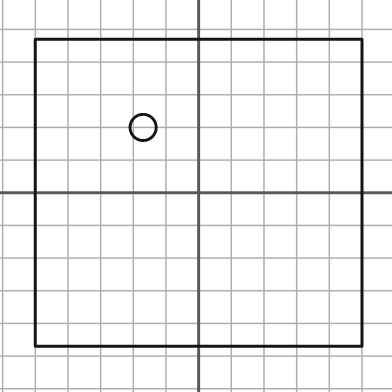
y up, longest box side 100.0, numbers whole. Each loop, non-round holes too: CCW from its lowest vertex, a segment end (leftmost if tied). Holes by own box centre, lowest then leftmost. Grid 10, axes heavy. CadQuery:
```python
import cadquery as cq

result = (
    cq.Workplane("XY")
    .moveTo(-50.0, -47.0)
    .lineTo(50.0, -47.0)
    .lineTo(50.0, 47.0)
    .lineTo(-50.0, 47.0)
    .close()
    .moveTo(-17.0, 20.0)
    .circle(4.0)
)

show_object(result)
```